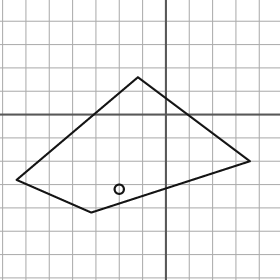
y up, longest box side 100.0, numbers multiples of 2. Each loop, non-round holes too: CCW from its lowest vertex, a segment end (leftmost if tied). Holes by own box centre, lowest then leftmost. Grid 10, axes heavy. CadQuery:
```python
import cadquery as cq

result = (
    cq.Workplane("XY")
    .moveTo(-32.0, -42.0)
    .lineTo(36.0, -20.0)
    .lineTo(-12.0, 16.0)
    .lineTo(-64.0, -28.0)
    .close()
    .moveTo(-20.0, -32.0)
    .circle(2.0)
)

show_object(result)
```